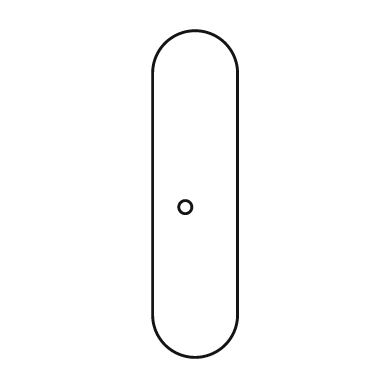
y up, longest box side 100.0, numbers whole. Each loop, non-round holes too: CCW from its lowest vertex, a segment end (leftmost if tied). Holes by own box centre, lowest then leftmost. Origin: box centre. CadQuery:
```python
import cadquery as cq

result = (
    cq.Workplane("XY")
    .moveTo(-13.0, -37.0)
    .threePointArc((0.0, -50.0), (13.0, -37.0))
    .lineTo(13.0, 37.0)
    .threePointArc((0.0, 50.0), (-13.0, 37.0))
    .close()
    .moveTo(-3.0, -4.0)
    .circle(2.0)
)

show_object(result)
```